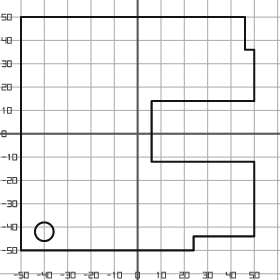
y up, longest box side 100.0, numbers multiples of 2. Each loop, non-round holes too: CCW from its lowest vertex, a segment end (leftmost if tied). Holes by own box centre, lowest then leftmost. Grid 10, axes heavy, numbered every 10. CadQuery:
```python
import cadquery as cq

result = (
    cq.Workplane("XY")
    .moveTo(-50.0, -50.0)
    .lineTo(24.0, -50.0)
    .lineTo(24.0, -44.0)
    .lineTo(50.0, -44.0)
    .lineTo(50.0, -12.0)
    .lineTo(6.0, -12.0)
    .lineTo(6.0, 14.0)
    .lineTo(50.0, 14.0)
    .lineTo(50.0, 36.0)
    .lineTo(46.0, 36.0)
    .lineTo(46.0, 50.0)
    .lineTo(-50.0, 50.0)
    .close()
    .moveTo(-40.0, -42.0)
    .circle(4.0)
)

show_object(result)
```